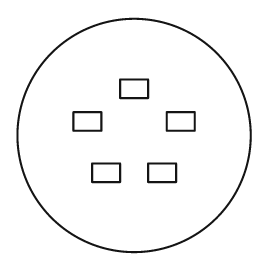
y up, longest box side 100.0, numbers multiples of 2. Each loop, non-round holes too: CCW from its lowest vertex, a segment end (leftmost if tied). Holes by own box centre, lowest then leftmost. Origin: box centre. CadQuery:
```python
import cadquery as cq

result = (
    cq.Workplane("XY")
    .moveTo(0.0, 0.0)
    .circle(50.0)
    .moveTo(-18.0, -20.0)
    .lineTo(-6.0, -20.0)
    .lineTo(-6.0, -12.0)
    .lineTo(-18.0, -12.0)
    .close()
    .moveTo(6.0, -20.0)
    .lineTo(18.0, -20.0)
    .lineTo(18.0, -12.0)
    .lineTo(6.0, -12.0)
    .close()
    .moveTo(-26.0, 2.0)
    .lineTo(-14.0, 2.0)
    .lineTo(-14.0, 10.0)
    .lineTo(-26.0, 10.0)
    .close()
    .moveTo(14.0, 2.0)
    .lineTo(26.0, 2.0)
    .lineTo(26.0, 10.0)
    .lineTo(14.0, 10.0)
    .close()
    .moveTo(-6.0, 16.0)
    .lineTo(6.0, 16.0)
    .lineTo(6.0, 24.0)
    .lineTo(-6.0, 24.0)
    .close()
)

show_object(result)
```